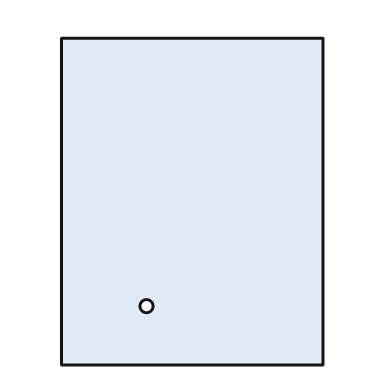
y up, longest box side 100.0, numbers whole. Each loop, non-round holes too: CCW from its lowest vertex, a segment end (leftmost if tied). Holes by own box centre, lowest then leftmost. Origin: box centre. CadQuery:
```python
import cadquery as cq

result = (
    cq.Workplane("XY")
    .moveTo(-40.0, -50.0)
    .lineTo(40.0, -50.0)
    .lineTo(40.0, 50.0)
    .lineTo(-40.0, 50.0)
    .close()
    .moveTo(-14.0, -32.0)
    .circle(2.0)
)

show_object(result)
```